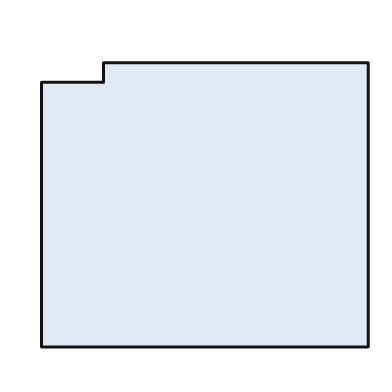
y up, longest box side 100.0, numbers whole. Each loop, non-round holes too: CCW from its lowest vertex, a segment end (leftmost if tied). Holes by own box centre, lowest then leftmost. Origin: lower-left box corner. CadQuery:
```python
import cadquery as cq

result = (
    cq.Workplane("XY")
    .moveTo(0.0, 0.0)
    .lineTo(100.0, 0.0)
    .lineTo(100.0, 87.0)
    .lineTo(19.0, 87.0)
    .lineTo(19.0, 81.0)
    .lineTo(0.0, 81.0)
    .close()
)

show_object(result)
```